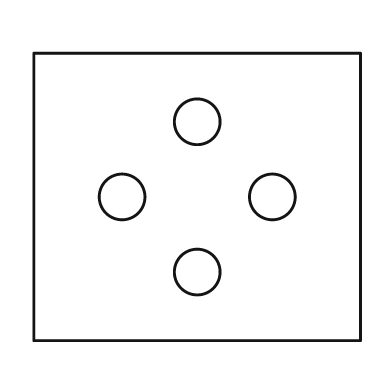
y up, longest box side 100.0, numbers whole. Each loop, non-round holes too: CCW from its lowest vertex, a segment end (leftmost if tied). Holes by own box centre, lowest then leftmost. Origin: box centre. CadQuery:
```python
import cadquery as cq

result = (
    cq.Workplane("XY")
    .moveTo(-50.0, -44.0)
    .lineTo(50.0, -44.0)
    .lineTo(50.0, 44.0)
    .lineTo(-50.0, 44.0)
    .close()
    .moveTo(0.0, -23.0)
    .circle(7.0)
    .moveTo(-23.0, 0.0)
    .circle(7.0)
    .moveTo(23.0, 0.0)
    .circle(7.0)
    .moveTo(0.0, 23.0)
    .circle(7.0)
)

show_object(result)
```